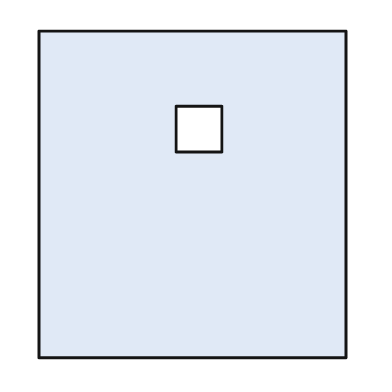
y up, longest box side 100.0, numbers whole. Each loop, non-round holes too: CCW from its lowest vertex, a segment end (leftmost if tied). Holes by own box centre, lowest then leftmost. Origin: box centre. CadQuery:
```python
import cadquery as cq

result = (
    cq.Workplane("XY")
    .moveTo(-47.0, -50.0)
    .lineTo(47.0, -50.0)
    .lineTo(47.0, 50.0)
    .lineTo(-47.0, 50.0)
    .close()
    .moveTo(-5.0, 13.0)
    .lineTo(9.0, 13.0)
    .lineTo(9.0, 27.0)
    .lineTo(-5.0, 27.0)
    .close()
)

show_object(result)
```